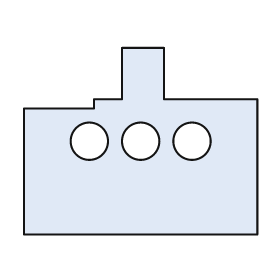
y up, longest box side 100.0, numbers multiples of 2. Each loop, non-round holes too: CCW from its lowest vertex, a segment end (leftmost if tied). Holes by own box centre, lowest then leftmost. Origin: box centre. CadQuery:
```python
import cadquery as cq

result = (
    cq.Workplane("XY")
    .moveTo(-50.0, -40.0)
    .lineTo(50.0, -40.0)
    .lineTo(50.0, 18.0)
    .lineTo(10.0, 18.0)
    .lineTo(10.0, 40.0)
    .lineTo(-8.0, 40.0)
    .lineTo(-8.0, 18.0)
    .lineTo(-20.0, 18.0)
    .lineTo(-20.0, 14.0)
    .lineTo(-50.0, 14.0)
    .close()
    .moveTo(-22.0, 0.0)
    .circle(8.0)
    .moveTo(0.0, 0.0)
    .circle(8.0)
    .moveTo(22.0, 0.0)
    .circle(8.0)
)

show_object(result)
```